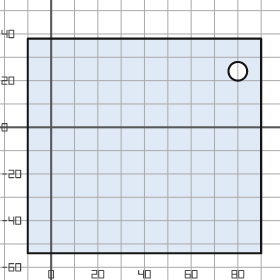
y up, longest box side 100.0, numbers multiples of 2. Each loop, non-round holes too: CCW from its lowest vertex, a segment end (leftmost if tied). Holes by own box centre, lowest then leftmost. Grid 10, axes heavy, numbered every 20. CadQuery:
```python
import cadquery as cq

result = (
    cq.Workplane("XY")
    .moveTo(-10.0, -54.0)
    .lineTo(90.0, -54.0)
    .lineTo(90.0, 38.0)
    .lineTo(-10.0, 38.0)
    .close()
    .moveTo(80.0, 24.0)
    .circle(4.0)
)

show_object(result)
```